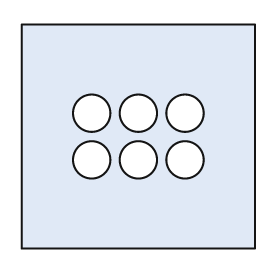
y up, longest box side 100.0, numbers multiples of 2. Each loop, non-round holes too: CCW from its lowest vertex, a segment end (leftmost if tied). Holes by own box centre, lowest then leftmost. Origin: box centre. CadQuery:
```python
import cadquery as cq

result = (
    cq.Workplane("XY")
    .moveTo(-50.0, -48.0)
    .lineTo(50.0, -48.0)
    .lineTo(50.0, 48.0)
    .lineTo(-50.0, 48.0)
    .close()
    .moveTo(-20.0, -10.0)
    .circle(8.0)
    .moveTo(0.0, -10.0)
    .circle(8.0)
    .moveTo(20.0, -10.0)
    .circle(8.0)
    .moveTo(-20.0, 10.0)
    .circle(8.0)
    .moveTo(0.0, 10.0)
    .circle(8.0)
    .moveTo(20.0, 10.0)
    .circle(8.0)
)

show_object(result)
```